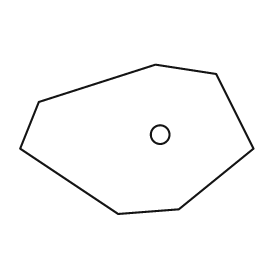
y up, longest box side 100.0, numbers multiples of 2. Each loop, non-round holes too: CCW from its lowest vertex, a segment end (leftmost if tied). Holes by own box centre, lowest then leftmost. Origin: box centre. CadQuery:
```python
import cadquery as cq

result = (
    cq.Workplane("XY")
    .moveTo(-8.0, -32.0)
    .lineTo(18.0, -30.0)
    .lineTo(50.0, -4.0)
    .lineTo(34.0, 28.0)
    .lineTo(8.0, 32.0)
    .lineTo(-42.0, 16.0)
    .lineTo(-50.0, -4.0)
    .close()
    .moveTo(10.0, 2.0)
    .circle(4.0)
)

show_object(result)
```